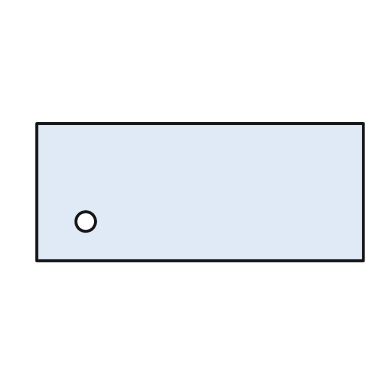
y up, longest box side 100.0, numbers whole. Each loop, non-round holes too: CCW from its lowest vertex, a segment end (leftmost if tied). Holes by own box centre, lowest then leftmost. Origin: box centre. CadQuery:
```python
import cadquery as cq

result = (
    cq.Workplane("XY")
    .moveTo(-50.0, -21.0)
    .lineTo(50.0, -21.0)
    .lineTo(50.0, 21.0)
    .lineTo(-50.0, 21.0)
    .close()
    .moveTo(-35.0, -9.0)
    .circle(3.0)
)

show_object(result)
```